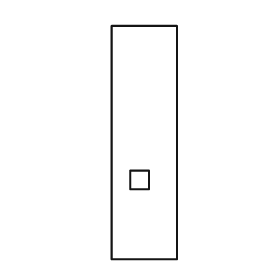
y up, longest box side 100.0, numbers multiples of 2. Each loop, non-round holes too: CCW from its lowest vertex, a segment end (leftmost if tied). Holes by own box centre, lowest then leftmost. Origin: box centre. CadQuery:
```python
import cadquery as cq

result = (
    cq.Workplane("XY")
    .moveTo(-14.0, -50.0)
    .lineTo(14.0, -50.0)
    .lineTo(14.0, 50.0)
    .lineTo(-14.0, 50.0)
    .close()
    .moveTo(-6.0, -20.0)
    .lineTo(2.0, -20.0)
    .lineTo(2.0, -12.0)
    .lineTo(-6.0, -12.0)
    .close()
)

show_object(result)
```